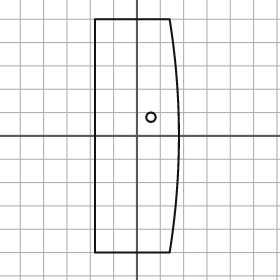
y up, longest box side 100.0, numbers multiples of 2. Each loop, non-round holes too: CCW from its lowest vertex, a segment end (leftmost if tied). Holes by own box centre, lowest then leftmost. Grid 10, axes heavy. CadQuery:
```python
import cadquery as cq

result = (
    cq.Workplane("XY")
    .moveTo(-18.0, -50.0)
    .lineTo(14.0, -50.0)
    .threePointArc((18.0, 0.0), (14.0, 50.0))
    .lineTo(-18.0, 50.0)
    .close()
    .moveTo(6.0, 8.0)
    .circle(2.0)
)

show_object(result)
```